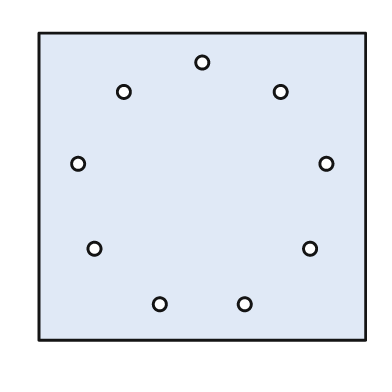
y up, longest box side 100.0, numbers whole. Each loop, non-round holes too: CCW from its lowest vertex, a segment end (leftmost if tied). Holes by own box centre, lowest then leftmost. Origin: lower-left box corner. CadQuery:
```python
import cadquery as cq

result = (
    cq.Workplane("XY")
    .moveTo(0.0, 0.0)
    .lineTo(100.0, 0.0)
    .lineTo(100.0, 94.0)
    .lineTo(0.0, 94.0)
    .close()
    .moveTo(37.0, 11.0)
    .circle(2.0)
    .moveTo(63.0, 11.0)
    .circle(2.0)
    .moveTo(17.0, 28.0)
    .circle(2.0)
    .moveTo(83.0, 28.0)
    .circle(2.0)
    .moveTo(12.0, 54.0)
    .circle(2.0)
    .moveTo(88.0, 54.0)
    .circle(2.0)
    .moveTo(26.0, 76.0)
    .circle(2.0)
    .moveTo(74.0, 76.0)
    .circle(2.0)
    .moveTo(50.0, 85.0)
    .circle(2.0)
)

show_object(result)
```